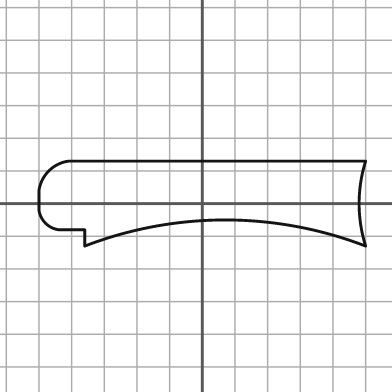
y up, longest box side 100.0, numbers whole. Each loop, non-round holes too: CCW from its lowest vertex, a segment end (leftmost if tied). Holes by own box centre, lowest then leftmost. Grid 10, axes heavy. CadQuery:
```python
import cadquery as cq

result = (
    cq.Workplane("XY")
    .moveTo(-36.0, -13.0)
    .threePointArc((7.0, -5.0), (50.0, -13.0))
    .threePointArc((48.0, 0.0), (50.0, 13.0))
    .lineTo(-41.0, 13.0)
    .threePointArc((-47.0, 10.0), (-50.0, 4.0))
    .lineTo(-50.0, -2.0)
    .threePointArc((-48.0, -6.0), (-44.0, -8.0))
    .lineTo(-36.0, -8.0)
    .close()
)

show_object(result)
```